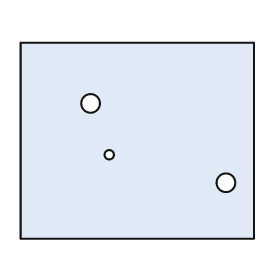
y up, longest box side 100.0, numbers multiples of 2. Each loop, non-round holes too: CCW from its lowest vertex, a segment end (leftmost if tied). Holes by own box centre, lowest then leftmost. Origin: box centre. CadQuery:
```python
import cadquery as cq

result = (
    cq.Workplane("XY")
    .moveTo(-50.0, -42.0)
    .lineTo(50.0, -42.0)
    .lineTo(50.0, 42.0)
    .lineTo(-50.0, 42.0)
    .close()
    .moveTo(38.0, -18.0)
    .circle(4.0)
    .moveTo(-12.0, -6.0)
    .circle(2.0)
    .moveTo(-20.0, 16.0)
    .circle(4.0)
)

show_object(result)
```